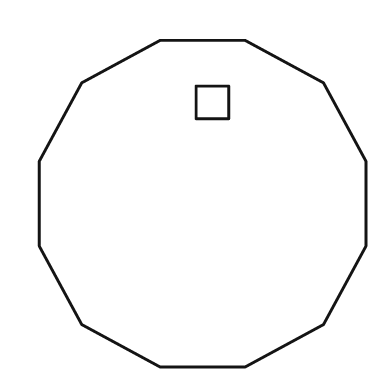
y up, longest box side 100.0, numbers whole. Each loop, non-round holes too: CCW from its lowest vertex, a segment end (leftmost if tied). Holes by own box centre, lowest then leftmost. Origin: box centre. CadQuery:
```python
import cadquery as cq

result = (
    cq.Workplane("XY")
    .moveTo(-13.0, -50.0)
    .lineTo(13.0, -50.0)
    .lineTo(37.0, -37.0)
    .lineTo(50.0, -13.0)
    .lineTo(50.0, 13.0)
    .lineTo(37.0, 37.0)
    .lineTo(13.0, 50.0)
    .lineTo(-13.0, 50.0)
    .lineTo(-37.0, 37.0)
    .lineTo(-50.0, 13.0)
    .lineTo(-50.0, -13.0)
    .lineTo(-37.0, -37.0)
    .close()
    .moveTo(-2.0, 26.0)
    .lineTo(8.0, 26.0)
    .lineTo(8.0, 36.0)
    .lineTo(-2.0, 36.0)
    .close()
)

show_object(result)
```